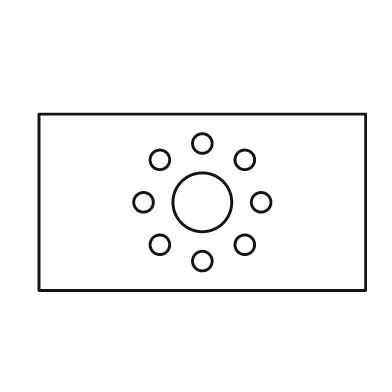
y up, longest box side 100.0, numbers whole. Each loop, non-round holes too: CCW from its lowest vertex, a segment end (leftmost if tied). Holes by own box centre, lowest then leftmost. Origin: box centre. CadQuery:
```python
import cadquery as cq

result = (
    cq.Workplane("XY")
    .moveTo(-50.0, -27.0)
    .lineTo(50.0, -27.0)
    .lineTo(50.0, 27.0)
    .lineTo(-50.0, 27.0)
    .close()
    .moveTo(0.0, -18.0)
    .circle(3.0)
    .moveTo(-13.0, -13.0)
    .circle(3.0)
    .moveTo(13.0, -13.0)
    .circle(3.0)
    .moveTo(-18.0, 0.0)
    .circle(3.0)
    .moveTo(0.0, 0.0)
    .circle(9.0)
    .moveTo(18.0, 0.0)
    .circle(3.0)
    .moveTo(-13.0, 13.0)
    .circle(3.0)
    .moveTo(13.0, 13.0)
    .circle(3.0)
    .moveTo(0.0, 18.0)
    .circle(3.0)
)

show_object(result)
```